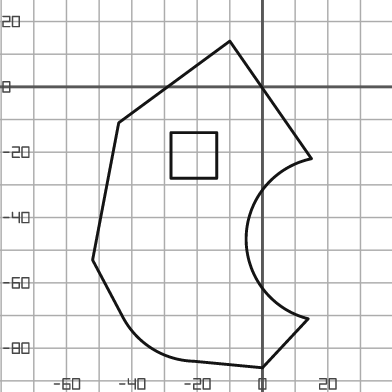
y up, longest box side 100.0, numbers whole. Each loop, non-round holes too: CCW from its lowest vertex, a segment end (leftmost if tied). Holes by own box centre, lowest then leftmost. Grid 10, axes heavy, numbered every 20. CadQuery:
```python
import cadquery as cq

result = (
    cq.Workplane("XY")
    .moveTo(0.0, -86.0)
    .lineTo(14.0, -71.0)
    .threePointArc((-5.0, -46.0), (15.0, -22.0))
    .lineTo(-10.0, 14.0)
    .lineTo(-44.0, -11.0)
    .lineTo(-52.0, -53.0)
    .lineTo(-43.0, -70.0)
    .threePointArc((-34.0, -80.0), (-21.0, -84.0))
    .close()
    .moveTo(-28.0, -28.0)
    .lineTo(-14.0, -28.0)
    .lineTo(-14.0, -14.0)
    .lineTo(-28.0, -14.0)
    .close()
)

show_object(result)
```